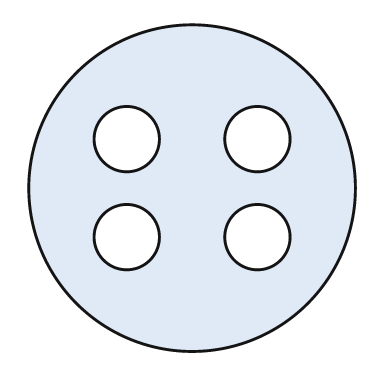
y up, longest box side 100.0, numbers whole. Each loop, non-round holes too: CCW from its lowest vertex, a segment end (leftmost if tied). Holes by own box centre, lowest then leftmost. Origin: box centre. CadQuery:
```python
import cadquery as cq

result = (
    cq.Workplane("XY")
    .moveTo(0.0, 0.0)
    .circle(50.0)
    .moveTo(-20.0, -15.0)
    .circle(10.0)
    .moveTo(20.0, -15.0)
    .circle(10.0)
    .moveTo(-20.0, 15.0)
    .circle(10.0)
    .moveTo(20.0, 15.0)
    .circle(10.0)
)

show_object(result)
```